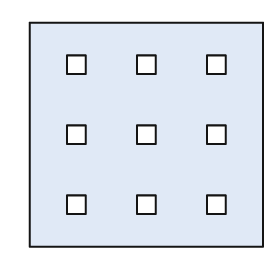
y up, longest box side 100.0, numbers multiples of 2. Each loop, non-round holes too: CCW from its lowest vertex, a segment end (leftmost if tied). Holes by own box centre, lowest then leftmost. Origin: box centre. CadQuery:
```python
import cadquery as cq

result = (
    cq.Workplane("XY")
    .moveTo(-50.0, -48.0)
    .lineTo(50.0, -48.0)
    .lineTo(50.0, 48.0)
    .lineTo(-50.0, 48.0)
    .close()
    .moveTo(-34.0, -34.0)
    .lineTo(-26.0, -34.0)
    .lineTo(-26.0, -26.0)
    .lineTo(-34.0, -26.0)
    .close()
    .moveTo(-4.0, -34.0)
    .lineTo(4.0, -34.0)
    .lineTo(4.0, -26.0)
    .lineTo(-4.0, -26.0)
    .close()
    .moveTo(26.0, -34.0)
    .lineTo(34.0, -34.0)
    .lineTo(34.0, -26.0)
    .lineTo(26.0, -26.0)
    .close()
    .moveTo(-34.0, -4.0)
    .lineTo(-26.0, -4.0)
    .lineTo(-26.0, 4.0)
    .lineTo(-34.0, 4.0)
    .close()
    .moveTo(-4.0, -4.0)
    .lineTo(4.0, -4.0)
    .lineTo(4.0, 4.0)
    .lineTo(-4.0, 4.0)
    .close()
    .moveTo(26.0, -4.0)
    .lineTo(34.0, -4.0)
    .lineTo(34.0, 4.0)
    .lineTo(26.0, 4.0)
    .close()
    .moveTo(-34.0, 26.0)
    .lineTo(-26.0, 26.0)
    .lineTo(-26.0, 34.0)
    .lineTo(-34.0, 34.0)
    .close()
    .moveTo(-4.0, 26.0)
    .lineTo(4.0, 26.0)
    .lineTo(4.0, 34.0)
    .lineTo(-4.0, 34.0)
    .close()
    .moveTo(26.0, 26.0)
    .lineTo(34.0, 26.0)
    .lineTo(34.0, 34.0)
    .lineTo(26.0, 34.0)
    .close()
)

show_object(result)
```